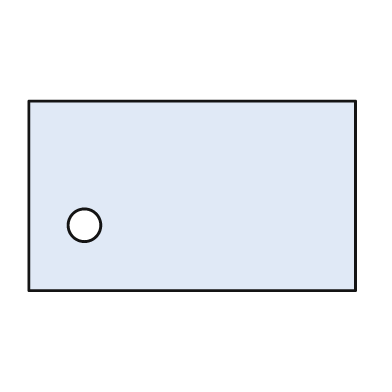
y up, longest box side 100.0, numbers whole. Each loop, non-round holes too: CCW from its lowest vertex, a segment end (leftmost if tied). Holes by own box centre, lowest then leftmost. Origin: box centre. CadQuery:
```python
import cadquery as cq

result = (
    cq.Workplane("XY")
    .moveTo(-50.0, -29.0)
    .lineTo(50.0, -29.0)
    .lineTo(50.0, 29.0)
    .lineTo(-50.0, 29.0)
    .close()
    .moveTo(-33.0, -9.0)
    .circle(5.0)
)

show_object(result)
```